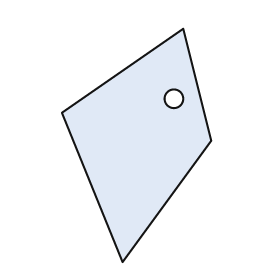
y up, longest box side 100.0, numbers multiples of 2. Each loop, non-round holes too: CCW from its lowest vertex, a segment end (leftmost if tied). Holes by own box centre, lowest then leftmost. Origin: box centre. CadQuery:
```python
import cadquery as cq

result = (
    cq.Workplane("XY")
    .moveTo(-6.0, -50.0)
    .lineTo(32.0, 2.0)
    .lineTo(20.0, 50.0)
    .lineTo(-32.0, 14.0)
    .close()
    .moveTo(16.0, 20.0)
    .circle(4.0)
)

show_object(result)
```